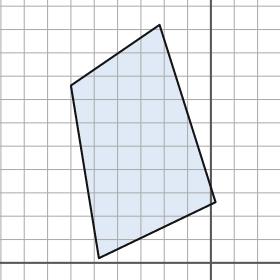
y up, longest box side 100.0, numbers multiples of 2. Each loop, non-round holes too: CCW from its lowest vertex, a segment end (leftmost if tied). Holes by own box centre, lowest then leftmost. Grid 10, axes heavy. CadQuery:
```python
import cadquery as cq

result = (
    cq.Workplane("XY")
    .moveTo(-48.0, 2.0)
    .lineTo(2.0, 26.0)
    .lineTo(-22.0, 102.0)
    .lineTo(-60.0, 76.0)
    .close()
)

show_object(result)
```